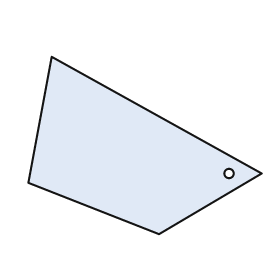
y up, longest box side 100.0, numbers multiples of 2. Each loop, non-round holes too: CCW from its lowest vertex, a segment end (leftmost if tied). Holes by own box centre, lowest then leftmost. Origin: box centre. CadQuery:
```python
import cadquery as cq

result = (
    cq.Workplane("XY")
    .moveTo(6.0, -38.0)
    .lineTo(50.0, -12.0)
    .lineTo(-40.0, 38.0)
    .lineTo(-50.0, -16.0)
    .close()
    .moveTo(36.0, -12.0)
    .circle(2.0)
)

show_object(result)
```